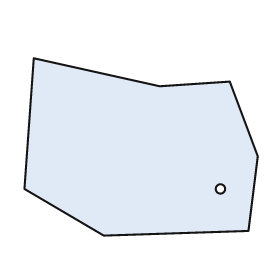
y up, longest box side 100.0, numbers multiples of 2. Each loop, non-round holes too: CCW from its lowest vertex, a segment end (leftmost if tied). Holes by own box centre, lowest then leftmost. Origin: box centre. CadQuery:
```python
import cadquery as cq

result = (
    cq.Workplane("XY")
    .moveTo(-16.0, -38.0)
    .lineTo(46.0, -36.0)
    .lineTo(50.0, -4.0)
    .lineTo(38.0, 28.0)
    .lineTo(8.0, 26.0)
    .lineTo(-46.0, 38.0)
    .lineTo(-50.0, -18.0)
    .close()
    .moveTo(34.0, -18.0)
    .circle(2.0)
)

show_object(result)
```